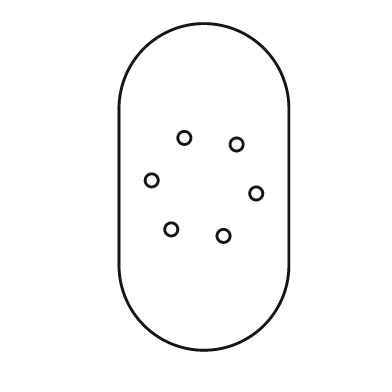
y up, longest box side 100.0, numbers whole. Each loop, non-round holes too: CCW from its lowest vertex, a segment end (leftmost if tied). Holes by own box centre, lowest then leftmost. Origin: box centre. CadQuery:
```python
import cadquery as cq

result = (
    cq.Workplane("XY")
    .moveTo(-26.0, -24.0)
    .threePointArc((0.0, -50.0), (26.0, -24.0))
    .lineTo(26.0, 24.0)
    .threePointArc((0.0, 50.0), (-26.0, 24.0))
    .close()
    .moveTo(6.0, -15.0)
    .circle(2.0)
    .moveTo(-10.0, -13.0)
    .circle(2.0)
    .moveTo(16.0, -2.0)
    .circle(2.0)
    .moveTo(-16.0, 2.0)
    .circle(2.0)
    .moveTo(10.0, 13.0)
    .circle(2.0)
    .moveTo(-6.0, 15.0)
    .circle(2.0)
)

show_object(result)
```